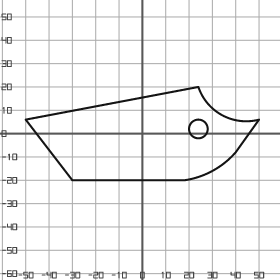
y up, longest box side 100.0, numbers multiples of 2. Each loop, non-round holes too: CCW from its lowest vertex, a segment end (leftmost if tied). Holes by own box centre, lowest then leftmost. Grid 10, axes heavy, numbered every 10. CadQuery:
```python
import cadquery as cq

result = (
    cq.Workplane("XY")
    .moveTo(-30.0, -20.0)
    .lineTo(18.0, -20.0)
    .threePointArc((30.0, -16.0), (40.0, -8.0))
    .lineTo(50.0, 6.0)
    .threePointArc((34.0, 8.0), (24.0, 20.0))
    .lineTo(-50.0, 6.0)
    .close()
    .moveTo(24.0, 2.0)
    .circle(4.0)
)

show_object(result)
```